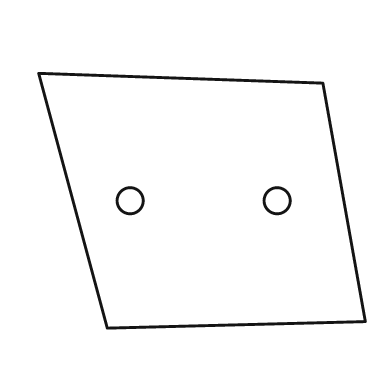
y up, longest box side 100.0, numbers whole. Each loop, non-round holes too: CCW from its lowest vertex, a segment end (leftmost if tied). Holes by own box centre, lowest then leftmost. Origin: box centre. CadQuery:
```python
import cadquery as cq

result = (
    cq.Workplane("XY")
    .moveTo(-29.0, -39.0)
    .lineTo(50.0, -37.0)
    .lineTo(37.0, 36.0)
    .lineTo(-50.0, 39.0)
    .close()
    .moveTo(-22.0, 0.0)
    .circle(4.0)
    .moveTo(23.0, 0.0)
    .circle(4.0)
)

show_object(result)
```